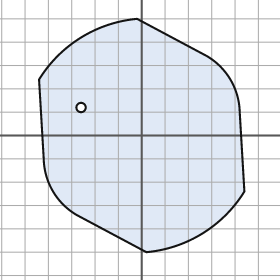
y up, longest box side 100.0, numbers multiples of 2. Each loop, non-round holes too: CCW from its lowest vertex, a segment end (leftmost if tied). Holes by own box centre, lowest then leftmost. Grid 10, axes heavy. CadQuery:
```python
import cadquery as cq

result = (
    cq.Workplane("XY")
    .moveTo(2.0, -50.0)
    .threePointArc((26.0, -42.0), (44.0, -24.0))
    .lineTo(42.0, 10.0)
    .threePointArc((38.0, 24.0), (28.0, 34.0))
    .lineTo(-2.0, 50.0)
    .threePointArc((-26.0, 42.0), (-44.0, 24.0))
    .lineTo(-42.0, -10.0)
    .threePointArc((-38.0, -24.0), (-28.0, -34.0))
    .close()
    .moveTo(-26.0, 12.0)
    .circle(2.0)
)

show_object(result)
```